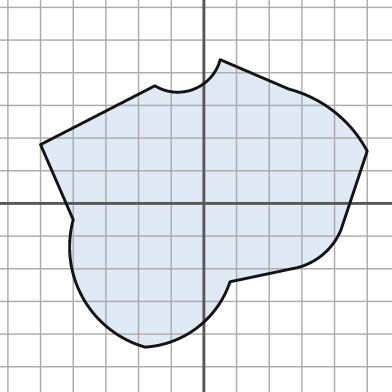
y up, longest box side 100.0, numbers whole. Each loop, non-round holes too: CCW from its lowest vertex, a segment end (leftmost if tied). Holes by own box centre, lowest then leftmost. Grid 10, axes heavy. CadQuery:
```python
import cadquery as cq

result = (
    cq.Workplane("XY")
    .moveTo(-18.0, -44.0)
    .threePointArc((-2.0, -38.0), (8.0, -24.0))
    .lineTo(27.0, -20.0)
    .threePointArc((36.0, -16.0), (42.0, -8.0))
    .lineTo(50.0, 16.0)
    .threePointArc((40.0, 28.0), (26.0, 35.0))
    .lineTo(5.0, 44.0)
    .threePointArc((-3.0, 35.0), (-15.0, 36.0))
    .lineTo(-50.0, 18.0)
    .lineTo(-40.0, -5.0)
    .threePointArc((-37.0, -29.0), (-18.0, -44.0))
    .close()
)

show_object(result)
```